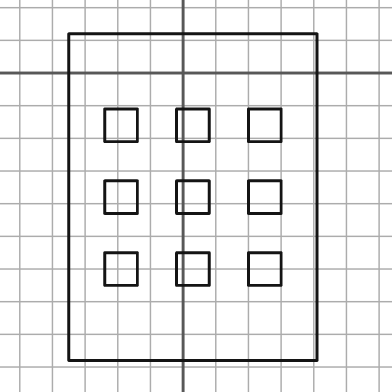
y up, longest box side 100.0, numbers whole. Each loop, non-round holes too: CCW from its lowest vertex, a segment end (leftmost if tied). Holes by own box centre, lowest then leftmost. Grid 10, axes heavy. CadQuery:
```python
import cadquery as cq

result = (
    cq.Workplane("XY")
    .moveTo(-35.0, -88.0)
    .lineTo(41.0, -88.0)
    .lineTo(41.0, 12.0)
    .lineTo(-35.0, 12.0)
    .close()
    .moveTo(-24.0, -65.0)
    .lineTo(-14.0, -65.0)
    .lineTo(-14.0, -55.0)
    .lineTo(-24.0, -55.0)
    .close()
    .moveTo(-2.0, -65.0)
    .lineTo(8.0, -65.0)
    .lineTo(8.0, -55.0)
    .lineTo(-2.0, -55.0)
    .close()
    .moveTo(20.0, -65.0)
    .lineTo(30.0, -65.0)
    .lineTo(30.0, -55.0)
    .lineTo(20.0, -55.0)
    .close()
    .moveTo(-24.0, -43.0)
    .lineTo(-14.0, -43.0)
    .lineTo(-14.0, -33.0)
    .lineTo(-24.0, -33.0)
    .close()
    .moveTo(-2.0, -43.0)
    .lineTo(8.0, -43.0)
    .lineTo(8.0, -33.0)
    .lineTo(-2.0, -33.0)
    .close()
    .moveTo(20.0, -43.0)
    .lineTo(30.0, -43.0)
    .lineTo(30.0, -33.0)
    .lineTo(20.0, -33.0)
    .close()
    .moveTo(-24.0, -21.0)
    .lineTo(-14.0, -21.0)
    .lineTo(-14.0, -11.0)
    .lineTo(-24.0, -11.0)
    .close()
    .moveTo(-2.0, -21.0)
    .lineTo(8.0, -21.0)
    .lineTo(8.0, -11.0)
    .lineTo(-2.0, -11.0)
    .close()
    .moveTo(20.0, -21.0)
    .lineTo(30.0, -21.0)
    .lineTo(30.0, -11.0)
    .lineTo(20.0, -11.0)
    .close()
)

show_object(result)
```